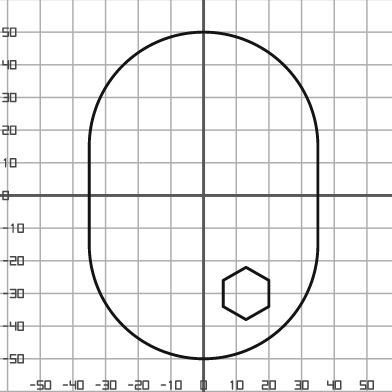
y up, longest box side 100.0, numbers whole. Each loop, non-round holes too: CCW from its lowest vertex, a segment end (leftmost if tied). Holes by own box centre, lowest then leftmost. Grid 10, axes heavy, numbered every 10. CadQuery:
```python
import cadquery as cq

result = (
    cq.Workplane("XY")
    .moveTo(-35.0, -15.0)
    .threePointArc((0.0, -50.0), (35.0, -15.0))
    .lineTo(35.0, 15.0)
    .threePointArc((0.0, 50.0), (-35.0, 15.0))
    .close()
    .moveTo(13.0, -38.0)
    .lineTo(20.0, -34.0)
    .lineTo(20.0, -26.0)
    .lineTo(13.0, -22.0)
    .lineTo(6.0, -26.0)
    .lineTo(6.0, -34.0)
    .close()
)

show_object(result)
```